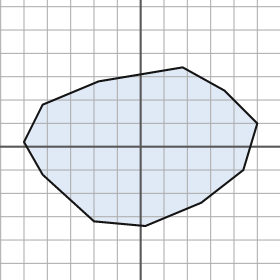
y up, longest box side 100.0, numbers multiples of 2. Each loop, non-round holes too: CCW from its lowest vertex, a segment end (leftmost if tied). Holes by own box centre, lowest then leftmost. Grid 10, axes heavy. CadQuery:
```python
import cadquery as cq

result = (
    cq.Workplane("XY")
    .moveTo(2.0, -34.0)
    .lineTo(26.0, -24.0)
    .lineTo(44.0, -10.0)
    .lineTo(50.0, 10.0)
    .lineTo(36.0, 24.0)
    .lineTo(18.0, 34.0)
    .lineTo(-18.0, 28.0)
    .lineTo(-42.0, 18.0)
    .lineTo(-50.0, 2.0)
    .lineTo(-42.0, -12.0)
    .lineTo(-20.0, -32.0)
    .close()
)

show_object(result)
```